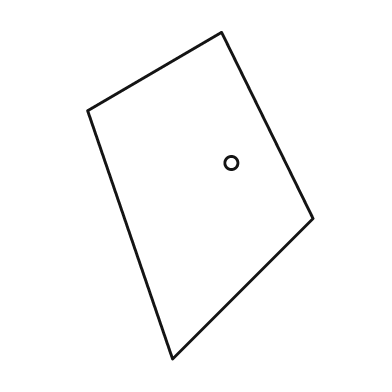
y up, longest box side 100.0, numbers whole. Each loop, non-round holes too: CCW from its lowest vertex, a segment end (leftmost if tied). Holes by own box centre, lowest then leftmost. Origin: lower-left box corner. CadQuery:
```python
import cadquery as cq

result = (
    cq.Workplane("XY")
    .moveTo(26.0, 0.0)
    .lineTo(69.0, 43.0)
    .lineTo(41.0, 100.0)
    .lineTo(0.0, 76.0)
    .close()
    .moveTo(44.0, 60.0)
    .circle(2.0)
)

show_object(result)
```